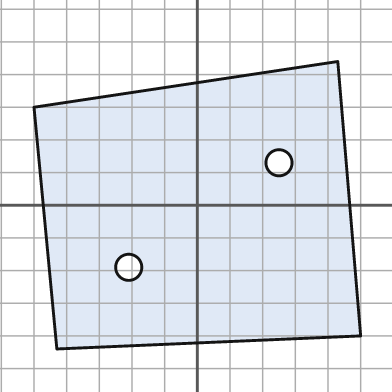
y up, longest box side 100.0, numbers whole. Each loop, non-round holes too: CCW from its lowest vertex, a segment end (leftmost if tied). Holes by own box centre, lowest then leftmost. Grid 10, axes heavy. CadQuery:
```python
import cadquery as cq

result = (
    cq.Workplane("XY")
    .moveTo(-43.0, -44.0)
    .lineTo(50.0, -40.0)
    .lineTo(43.0, 44.0)
    .lineTo(-50.0, 30.0)
    .close()
    .moveTo(-21.0, -19.0)
    .circle(4.0)
    .moveTo(25.0, 13.0)
    .circle(4.0)
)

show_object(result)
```